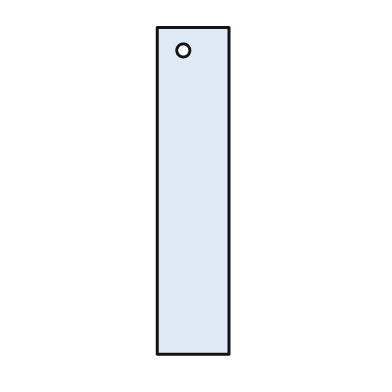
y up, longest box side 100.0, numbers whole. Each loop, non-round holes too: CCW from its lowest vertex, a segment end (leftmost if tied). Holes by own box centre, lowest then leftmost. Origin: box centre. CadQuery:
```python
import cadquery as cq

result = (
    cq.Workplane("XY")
    .moveTo(-11.0, -50.0)
    .lineTo(11.0, -50.0)
    .lineTo(11.0, 50.0)
    .lineTo(-11.0, 50.0)
    .close()
    .moveTo(-3.0, 43.0)
    .circle(2.0)
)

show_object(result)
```